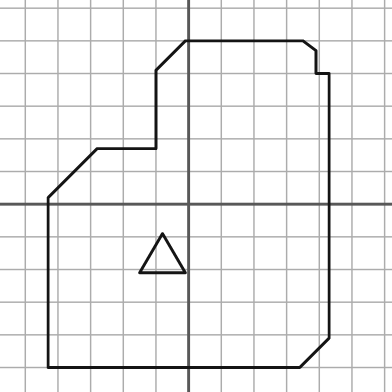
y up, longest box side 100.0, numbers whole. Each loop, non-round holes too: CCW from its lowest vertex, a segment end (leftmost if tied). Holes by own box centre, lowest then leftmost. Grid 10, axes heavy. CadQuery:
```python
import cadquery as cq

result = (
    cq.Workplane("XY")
    .moveTo(-43.0, -50.0)
    .lineTo(34.0, -50.0)
    .lineTo(43.0, -41.0)
    .lineTo(43.0, 40.0)
    .lineTo(39.0, 40.0)
    .lineTo(39.0, 47.0)
    .lineTo(35.0, 50.0)
    .lineTo(-1.0, 50.0)
    .lineTo(-10.0, 41.0)
    .lineTo(-10.0, 17.0)
    .lineTo(-28.0, 17.0)
    .lineTo(-43.0, 2.0)
    .close()
    .moveTo(-15.0, -21.0)
    .lineTo(-1.0, -21.0)
    .lineTo(-8.0, -9.0)
    .close()
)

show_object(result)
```